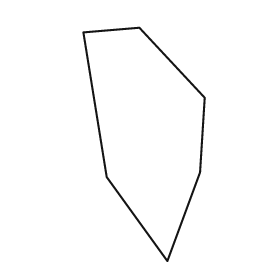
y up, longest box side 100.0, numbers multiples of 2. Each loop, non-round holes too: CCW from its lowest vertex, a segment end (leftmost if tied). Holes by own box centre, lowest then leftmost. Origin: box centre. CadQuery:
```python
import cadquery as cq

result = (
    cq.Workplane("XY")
    .moveTo(10.0, -50.0)
    .lineTo(24.0, -12.0)
    .lineTo(26.0, 20.0)
    .lineTo(-2.0, 50.0)
    .lineTo(-26.0, 48.0)
    .lineTo(-16.0, -14.0)
    .close()
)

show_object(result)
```